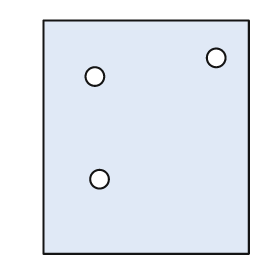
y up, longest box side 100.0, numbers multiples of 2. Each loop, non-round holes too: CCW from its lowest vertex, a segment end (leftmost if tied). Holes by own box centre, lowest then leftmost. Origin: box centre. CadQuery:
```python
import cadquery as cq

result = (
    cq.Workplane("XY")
    .moveTo(-44.0, -50.0)
    .lineTo(44.0, -50.0)
    .lineTo(44.0, 50.0)
    .lineTo(-44.0, 50.0)
    .close()
    .moveTo(-20.0, -18.0)
    .circle(4.0)
    .moveTo(-22.0, 26.0)
    .circle(4.0)
    .moveTo(30.0, 34.0)
    .circle(4.0)
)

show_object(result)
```